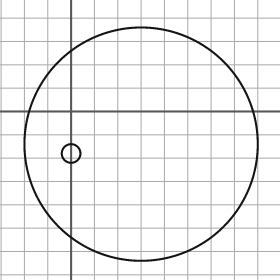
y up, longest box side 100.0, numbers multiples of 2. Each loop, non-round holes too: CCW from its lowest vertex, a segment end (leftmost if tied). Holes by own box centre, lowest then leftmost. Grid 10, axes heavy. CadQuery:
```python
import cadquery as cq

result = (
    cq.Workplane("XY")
    .moveTo(30.0, -14.0)
    .circle(50.0)
    .moveTo(0.0, -18.0)
    .circle(4.0)
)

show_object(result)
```